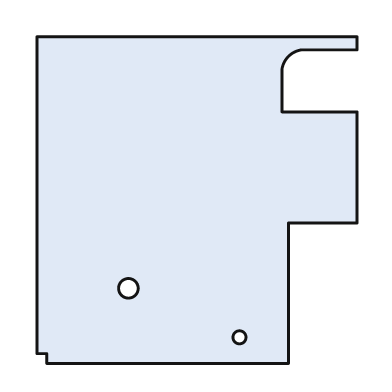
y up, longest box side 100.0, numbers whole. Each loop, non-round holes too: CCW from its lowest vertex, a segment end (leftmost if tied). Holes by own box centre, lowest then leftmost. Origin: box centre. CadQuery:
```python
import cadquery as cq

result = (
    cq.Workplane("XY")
    .moveTo(-46.0, -50.0)
    .lineTo(28.0, -50.0)
    .lineTo(28.0, -7.0)
    .lineTo(49.0, -7.0)
    .lineTo(49.0, 27.0)
    .lineTo(26.0, 27.0)
    .lineTo(26.0, 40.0)
    .threePointArc((28.0, 44.0), (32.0, 46.0))
    .lineTo(49.0, 46.0)
    .lineTo(49.0, 50.0)
    .lineTo(-49.0, 50.0)
    .lineTo(-49.0, -47.0)
    .lineTo(-46.0, -47.0)
    .close()
    .moveTo(13.0, -42.0)
    .circle(2.0)
    .moveTo(-21.0, -27.0)
    .circle(3.0)
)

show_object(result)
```